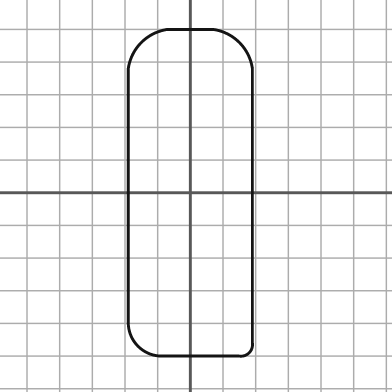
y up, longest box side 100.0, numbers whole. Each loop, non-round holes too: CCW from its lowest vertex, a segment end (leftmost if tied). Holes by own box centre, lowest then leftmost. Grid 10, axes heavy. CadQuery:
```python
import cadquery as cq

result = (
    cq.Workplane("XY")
    .moveTo(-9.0, -50.0)
    .lineTo(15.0, -50.0)
    .threePointArc((18.0, -49.0), (19.0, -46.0))
    .lineTo(19.0, 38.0)
    .threePointArc((15.0, 46.0), (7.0, 50.0))
    .lineTo(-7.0, 50.0)
    .threePointArc((-15.0, 46.0), (-19.0, 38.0))
    .lineTo(-19.0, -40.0)
    .threePointArc((-16.0, -47.0), (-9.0, -50.0))
    .close()
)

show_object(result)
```